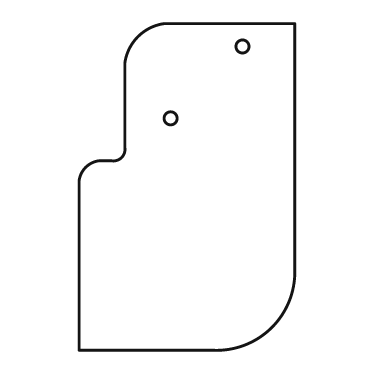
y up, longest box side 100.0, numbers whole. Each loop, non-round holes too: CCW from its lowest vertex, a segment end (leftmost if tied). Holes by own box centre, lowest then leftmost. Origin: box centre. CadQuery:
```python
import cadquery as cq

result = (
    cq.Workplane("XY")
    .moveTo(-33.0, -50.0)
    .lineTo(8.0, -50.0)
    .threePointArc((26.0, -43.0), (33.0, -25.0))
    .lineTo(33.0, 50.0)
    .lineTo(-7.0, 50.0)
    .threePointArc((-15.0, 46.0), (-19.0, 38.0))
    .lineTo(-19.0, 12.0)
    .threePointArc((-20.0, 9.0), (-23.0, 8.0))
    .lineTo(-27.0, 8.0)
    .threePointArc((-31.0, 6.0), (-33.0, 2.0))
    .close()
    .moveTo(-5.0, 21.0)
    .circle(2.0)
    .moveTo(17.0, 43.0)
    .circle(2.0)
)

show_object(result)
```